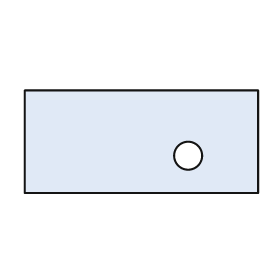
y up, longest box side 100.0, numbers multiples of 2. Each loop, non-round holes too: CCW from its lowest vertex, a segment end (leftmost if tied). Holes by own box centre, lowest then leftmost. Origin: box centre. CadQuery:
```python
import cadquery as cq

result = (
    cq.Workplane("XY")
    .moveTo(-50.0, -22.0)
    .lineTo(50.0, -22.0)
    .lineTo(50.0, 22.0)
    .lineTo(-50.0, 22.0)
    .close()
    .moveTo(20.0, -6.0)
    .circle(6.0)
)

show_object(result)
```